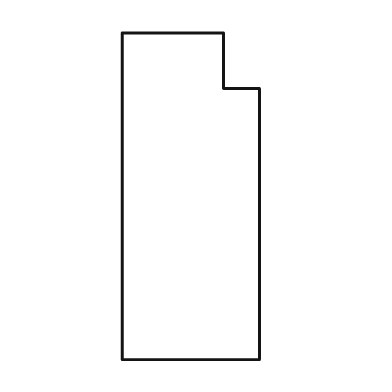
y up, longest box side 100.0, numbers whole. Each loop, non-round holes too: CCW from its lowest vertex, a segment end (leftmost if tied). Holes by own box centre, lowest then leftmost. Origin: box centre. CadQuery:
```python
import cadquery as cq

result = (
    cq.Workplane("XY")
    .moveTo(-21.0, -50.0)
    .lineTo(21.0, -50.0)
    .lineTo(21.0, 33.0)
    .lineTo(10.0, 33.0)
    .lineTo(10.0, 50.0)
    .lineTo(-21.0, 50.0)
    .close()
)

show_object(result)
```